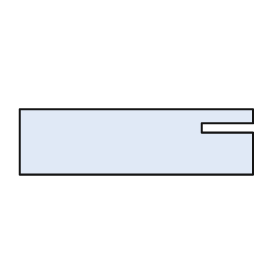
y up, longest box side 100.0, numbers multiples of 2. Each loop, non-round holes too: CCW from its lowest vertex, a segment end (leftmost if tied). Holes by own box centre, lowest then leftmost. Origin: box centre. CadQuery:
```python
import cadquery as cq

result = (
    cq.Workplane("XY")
    .moveTo(-50.0, -14.0)
    .lineTo(50.0, -14.0)
    .lineTo(50.0, 4.0)
    .lineTo(28.0, 4.0)
    .lineTo(28.0, 8.0)
    .lineTo(50.0, 8.0)
    .lineTo(50.0, 14.0)
    .lineTo(-50.0, 14.0)
    .close()
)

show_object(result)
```